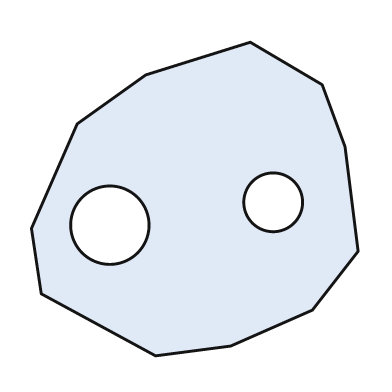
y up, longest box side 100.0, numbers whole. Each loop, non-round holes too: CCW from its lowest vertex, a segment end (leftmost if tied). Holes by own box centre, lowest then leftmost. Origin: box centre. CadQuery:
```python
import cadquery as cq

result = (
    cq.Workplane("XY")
    .moveTo(-12.0, -48.0)
    .lineTo(11.0, -45.0)
    .lineTo(36.0, -34.0)
    .lineTo(50.0, -16.0)
    .lineTo(46.0, 16.0)
    .lineTo(39.0, 35.0)
    .lineTo(17.0, 48.0)
    .lineTo(-15.0, 38.0)
    .lineTo(-36.0, 23.0)
    .lineTo(-50.0, -9.0)
    .lineTo(-47.0, -29.0)
    .close()
    .moveTo(-26.0, -8.0)
    .circle(12.0)
    .moveTo(24.0, -1.0)
    .circle(9.0)
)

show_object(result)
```